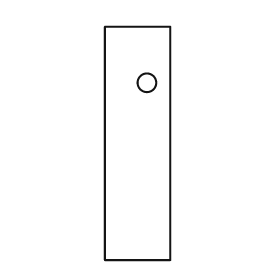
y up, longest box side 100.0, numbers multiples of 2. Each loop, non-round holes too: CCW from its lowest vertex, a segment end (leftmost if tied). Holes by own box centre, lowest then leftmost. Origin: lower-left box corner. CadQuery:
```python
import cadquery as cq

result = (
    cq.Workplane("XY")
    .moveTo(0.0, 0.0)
    .lineTo(28.0, 0.0)
    .lineTo(28.0, 100.0)
    .lineTo(0.0, 100.0)
    .close()
    .moveTo(18.0, 76.0)
    .circle(4.0)
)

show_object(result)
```